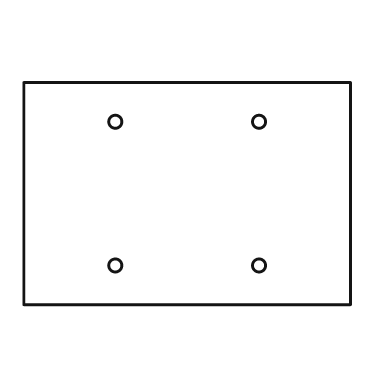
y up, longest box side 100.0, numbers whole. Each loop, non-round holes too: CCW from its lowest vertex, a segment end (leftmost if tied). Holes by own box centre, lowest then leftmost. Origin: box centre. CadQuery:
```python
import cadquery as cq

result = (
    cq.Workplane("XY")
    .moveTo(-50.0, -34.0)
    .lineTo(50.0, -34.0)
    .lineTo(50.0, 34.0)
    .lineTo(-50.0, 34.0)
    .close()
    .moveTo(-22.0, -22.0)
    .circle(2.0)
    .moveTo(22.0, -22.0)
    .circle(2.0)
    .moveTo(-22.0, 22.0)
    .circle(2.0)
    .moveTo(22.0, 22.0)
    .circle(2.0)
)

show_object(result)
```